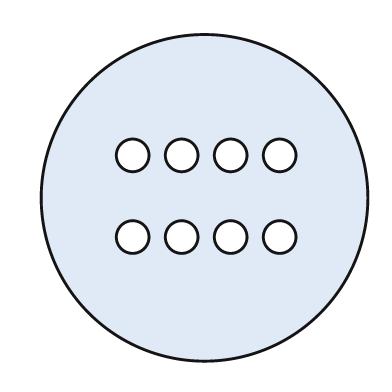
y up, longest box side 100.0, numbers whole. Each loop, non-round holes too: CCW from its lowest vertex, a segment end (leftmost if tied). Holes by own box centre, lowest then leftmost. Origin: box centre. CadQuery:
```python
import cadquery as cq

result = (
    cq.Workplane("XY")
    .moveTo(0.0, 0.0)
    .circle(50.0)
    .moveTo(-22.0, -12.0)
    .circle(5.0)
    .moveTo(-7.0, -12.0)
    .circle(5.0)
    .moveTo(8.0, -12.0)
    .circle(5.0)
    .moveTo(23.0, -12.0)
    .circle(5.0)
    .moveTo(-22.0, 13.0)
    .circle(5.0)
    .moveTo(-7.0, 13.0)
    .circle(5.0)
    .moveTo(8.0, 13.0)
    .circle(5.0)
    .moveTo(23.0, 13.0)
    .circle(5.0)
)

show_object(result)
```